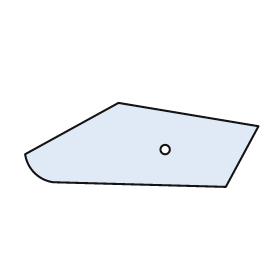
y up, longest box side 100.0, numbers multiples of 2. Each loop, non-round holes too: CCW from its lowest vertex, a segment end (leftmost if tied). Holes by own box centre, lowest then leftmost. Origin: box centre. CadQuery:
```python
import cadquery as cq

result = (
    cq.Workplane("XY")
    .moveTo(36.0, -18.0)
    .lineTo(50.0, 8.0)
    .lineTo(-10.0, 18.0)
    .lineTo(-50.0, -4.0)
    .threePointArc((-46.0, -12.0), (-38.0, -16.0))
    .close()
    .moveTo(10.0, -2.0)
    .circle(2.0)
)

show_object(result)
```